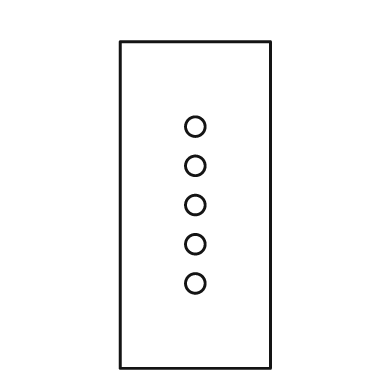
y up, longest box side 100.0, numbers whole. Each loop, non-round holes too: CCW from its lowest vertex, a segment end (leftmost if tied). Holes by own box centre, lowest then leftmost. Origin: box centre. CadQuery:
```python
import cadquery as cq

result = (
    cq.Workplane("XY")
    .moveTo(-23.0, -50.0)
    .lineTo(23.0, -50.0)
    .lineTo(23.0, 50.0)
    .lineTo(-23.0, 50.0)
    .close()
    .moveTo(0.0, -24.0)
    .circle(3.0)
    .moveTo(0.0, -12.0)
    .circle(3.0)
    .moveTo(0.0, 0.0)
    .circle(3.0)
    .moveTo(0.0, 12.0)
    .circle(3.0)
    .moveTo(0.0, 24.0)
    .circle(3.0)
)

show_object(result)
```